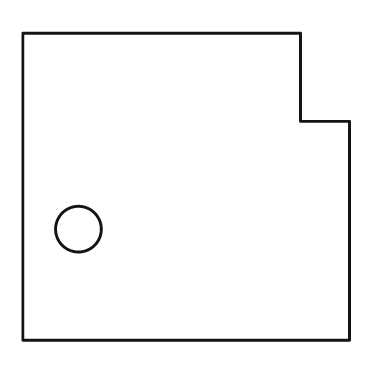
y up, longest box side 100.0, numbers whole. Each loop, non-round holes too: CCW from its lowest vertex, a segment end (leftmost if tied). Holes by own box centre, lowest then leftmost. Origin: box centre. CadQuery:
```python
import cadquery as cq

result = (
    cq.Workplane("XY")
    .moveTo(-50.0, -47.0)
    .lineTo(50.0, -47.0)
    .lineTo(50.0, 20.0)
    .lineTo(35.0, 20.0)
    .lineTo(35.0, 47.0)
    .lineTo(-50.0, 47.0)
    .close()
    .moveTo(-33.0, -13.0)
    .circle(7.0)
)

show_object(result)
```